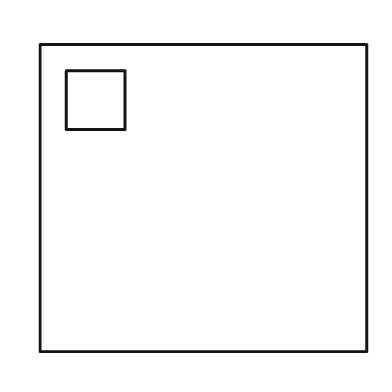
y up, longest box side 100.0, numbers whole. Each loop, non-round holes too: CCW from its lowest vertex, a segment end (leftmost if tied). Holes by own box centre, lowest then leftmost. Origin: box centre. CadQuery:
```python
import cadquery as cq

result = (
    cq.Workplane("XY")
    .moveTo(-50.0, -47.0)
    .lineTo(50.0, -47.0)
    .lineTo(50.0, 47.0)
    .lineTo(-50.0, 47.0)
    .close()
    .moveTo(-42.0, 21.0)
    .lineTo(-24.0, 21.0)
    .lineTo(-24.0, 39.0)
    .lineTo(-42.0, 39.0)
    .close()
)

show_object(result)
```